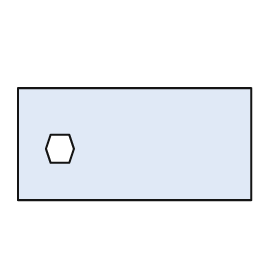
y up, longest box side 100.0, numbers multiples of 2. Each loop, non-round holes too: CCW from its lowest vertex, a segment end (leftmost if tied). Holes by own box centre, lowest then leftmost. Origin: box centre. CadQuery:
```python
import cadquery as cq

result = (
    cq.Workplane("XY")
    .moveTo(-50.0, -24.0)
    .lineTo(50.0, -24.0)
    .lineTo(50.0, 24.0)
    .lineTo(-50.0, 24.0)
    .close()
    .moveTo(-36.0, -8.0)
    .lineTo(-28.0, -8.0)
    .lineTo(-26.0, -2.0)
    .lineTo(-28.0, 4.0)
    .lineTo(-36.0, 4.0)
    .lineTo(-38.0, -2.0)
    .close()
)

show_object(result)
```